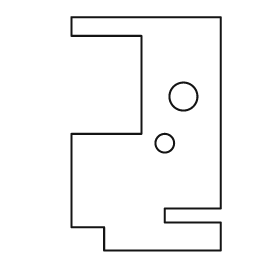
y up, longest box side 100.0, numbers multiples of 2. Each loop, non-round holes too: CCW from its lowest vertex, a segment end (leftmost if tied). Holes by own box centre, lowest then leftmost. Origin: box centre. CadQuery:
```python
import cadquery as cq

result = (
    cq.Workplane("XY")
    .moveTo(-18.0, -50.0)
    .lineTo(32.0, -50.0)
    .lineTo(32.0, -38.0)
    .lineTo(8.0, -38.0)
    .lineTo(8.0, -32.0)
    .lineTo(32.0, -32.0)
    .lineTo(32.0, 50.0)
    .lineTo(-32.0, 50.0)
    .lineTo(-32.0, 42.0)
    .lineTo(-2.0, 42.0)
    .lineTo(-2.0, 0.0)
    .lineTo(-32.0, 0.0)
    .lineTo(-32.0, -40.0)
    .lineTo(-18.0, -40.0)
    .close()
    .moveTo(8.0, -4.0)
    .circle(4.0)
    .moveTo(16.0, 16.0)
    .circle(6.0)
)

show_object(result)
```